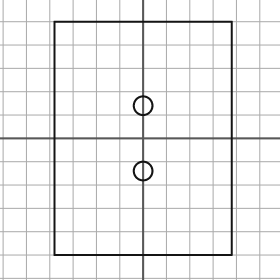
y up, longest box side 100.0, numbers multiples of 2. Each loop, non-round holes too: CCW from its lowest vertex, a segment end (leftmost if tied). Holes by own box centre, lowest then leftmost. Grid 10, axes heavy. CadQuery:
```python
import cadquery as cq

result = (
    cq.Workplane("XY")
    .moveTo(-38.0, -50.0)
    .lineTo(38.0, -50.0)
    .lineTo(38.0, 50.0)
    .lineTo(-38.0, 50.0)
    .close()
    .moveTo(0.0, -14.0)
    .circle(4.0)
    .moveTo(0.0, 14.0)
    .circle(4.0)
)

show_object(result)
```